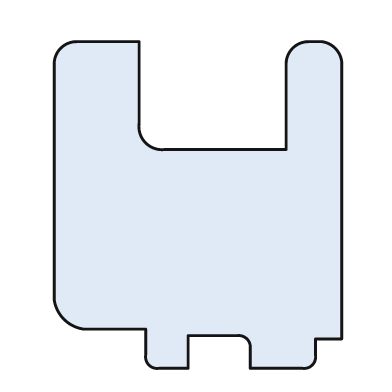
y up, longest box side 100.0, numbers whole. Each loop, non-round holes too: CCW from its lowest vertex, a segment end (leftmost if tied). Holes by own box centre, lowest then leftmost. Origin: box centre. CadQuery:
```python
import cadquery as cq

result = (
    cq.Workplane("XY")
    .moveTo(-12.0, -50.0)
    .lineTo(-3.0, -50.0)
    .lineTo(-3.0, -40.0)
    .lineTo(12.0, -40.0)
    .threePointArc((15.0, -41.0), (16.0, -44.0))
    .lineTo(16.0, -50.0)
    .lineTo(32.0, -50.0)
    .threePointArc((35.0, -49.0), (36.0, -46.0))
    .lineTo(36.0, -41.0)
    .lineTo(44.0, -41.0)
    .lineTo(44.0, 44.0)
    .threePointArc((42.0, 48.0), (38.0, 50.0))
    .lineTo(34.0, 50.0)
    .threePointArc((29.0, 48.0), (27.0, 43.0))
    .lineTo(27.0, 17.0)
    .lineTo(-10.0, 17.0)
    .threePointArc((-16.0, 19.0), (-18.0, 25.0))
    .lineTo(-18.0, 50.0)
    .lineTo(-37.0, 50.0)
    .threePointArc((-42.0, 48.0), (-44.0, 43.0))
    .lineTo(-44.0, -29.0)
    .threePointArc((-41.0, -35.0), (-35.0, -38.0))
    .lineTo(-16.0, -38.0)
    .lineTo(-16.0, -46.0)
    .threePointArc((-15.0, -49.0), (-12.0, -50.0))
    .close()
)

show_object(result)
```